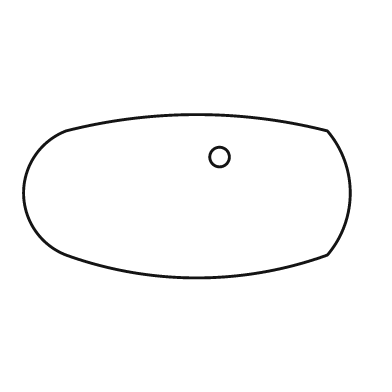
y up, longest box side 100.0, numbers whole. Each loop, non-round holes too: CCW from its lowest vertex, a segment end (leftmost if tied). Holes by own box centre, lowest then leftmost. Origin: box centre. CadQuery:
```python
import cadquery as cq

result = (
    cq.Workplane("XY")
    .moveTo(-37.0, -18.0)
    .threePointArc((3.0, -25.0), (43.0, -18.0))
    .threePointArc((50.0, 1.0), (43.0, 20.0))
    .threePointArc((3.0, 25.0), (-37.0, 20.0))
    .threePointArc((-50.0, 1.0), (-37.0, -18.0))
    .close()
    .moveTo(10.0, 12.0)
    .circle(3.0)
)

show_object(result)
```